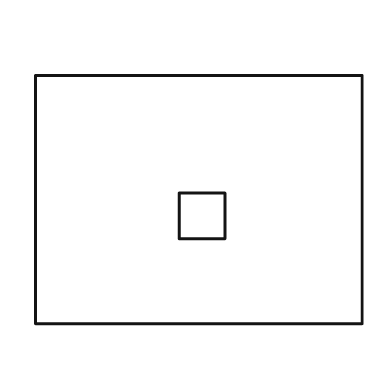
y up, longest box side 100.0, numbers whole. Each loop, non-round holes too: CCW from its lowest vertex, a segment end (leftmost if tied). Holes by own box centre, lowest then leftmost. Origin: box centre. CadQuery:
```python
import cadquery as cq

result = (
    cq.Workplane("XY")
    .moveTo(-50.0, -38.0)
    .lineTo(50.0, -38.0)
    .lineTo(50.0, 38.0)
    .lineTo(-50.0, 38.0)
    .close()
    .moveTo(-6.0, -12.0)
    .lineTo(8.0, -12.0)
    .lineTo(8.0, 2.0)
    .lineTo(-6.0, 2.0)
    .close()
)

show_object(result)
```